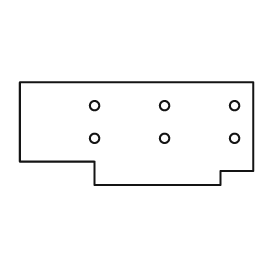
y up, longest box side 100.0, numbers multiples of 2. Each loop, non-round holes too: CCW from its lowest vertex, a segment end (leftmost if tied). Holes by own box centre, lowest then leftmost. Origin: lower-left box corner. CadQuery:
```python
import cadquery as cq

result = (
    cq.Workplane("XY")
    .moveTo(32.0, 0.0)
    .lineTo(86.0, 0.0)
    .lineTo(86.0, 6.0)
    .lineTo(100.0, 6.0)
    .lineTo(100.0, 44.0)
    .lineTo(0.0, 44.0)
    .lineTo(0.0, 10.0)
    .lineTo(32.0, 10.0)
    .close()
    .moveTo(32.0, 20.0)
    .circle(2.0)
    .moveTo(62.0, 20.0)
    .circle(2.0)
    .moveTo(92.0, 20.0)
    .circle(2.0)
    .moveTo(32.0, 34.0)
    .circle(2.0)
    .moveTo(62.0, 34.0)
    .circle(2.0)
    .moveTo(92.0, 34.0)
    .circle(2.0)
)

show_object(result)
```